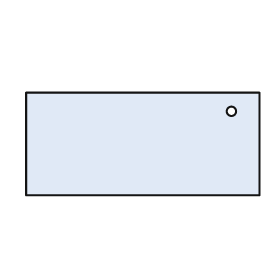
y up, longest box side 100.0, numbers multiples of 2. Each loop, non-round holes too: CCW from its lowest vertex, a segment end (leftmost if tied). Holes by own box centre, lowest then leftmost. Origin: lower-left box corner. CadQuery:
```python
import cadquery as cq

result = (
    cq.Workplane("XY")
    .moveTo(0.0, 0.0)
    .lineTo(100.0, 0.0)
    .lineTo(100.0, 44.0)
    .lineTo(0.0, 44.0)
    .close()
    .moveTo(88.0, 36.0)
    .circle(2.0)
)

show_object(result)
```